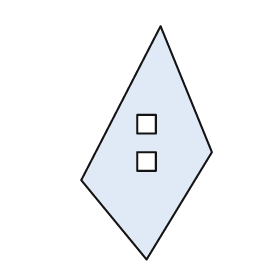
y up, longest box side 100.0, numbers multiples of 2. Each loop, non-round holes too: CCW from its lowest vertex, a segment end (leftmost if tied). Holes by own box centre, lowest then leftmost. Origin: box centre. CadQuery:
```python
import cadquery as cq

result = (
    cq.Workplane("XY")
    .moveTo(0.0, -50.0)
    .lineTo(28.0, -4.0)
    .lineTo(6.0, 50.0)
    .lineTo(-28.0, -16.0)
    .close()
    .moveTo(-4.0, -12.0)
    .lineTo(4.0, -12.0)
    .lineTo(4.0, -4.0)
    .lineTo(-4.0, -4.0)
    .close()
    .moveTo(-4.0, 4.0)
    .lineTo(4.0, 4.0)
    .lineTo(4.0, 12.0)
    .lineTo(-4.0, 12.0)
    .close()
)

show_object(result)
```